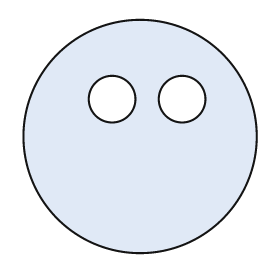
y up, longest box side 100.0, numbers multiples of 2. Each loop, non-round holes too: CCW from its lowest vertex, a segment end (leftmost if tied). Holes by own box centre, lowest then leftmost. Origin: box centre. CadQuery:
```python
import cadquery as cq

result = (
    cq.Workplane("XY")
    .moveTo(0.0, 0.0)
    .circle(50.0)
    .moveTo(-12.0, 16.0)
    .circle(10.0)
    .moveTo(18.0, 16.0)
    .circle(10.0)
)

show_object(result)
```